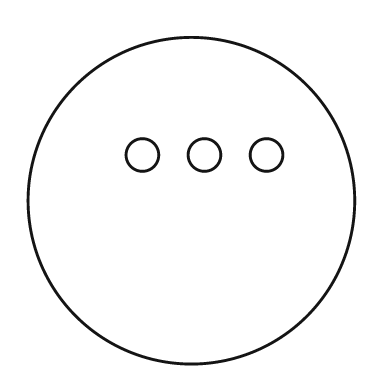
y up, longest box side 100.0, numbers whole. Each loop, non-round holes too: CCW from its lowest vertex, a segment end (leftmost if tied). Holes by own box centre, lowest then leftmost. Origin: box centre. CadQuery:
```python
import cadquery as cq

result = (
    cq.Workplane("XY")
    .moveTo(0.0, 0.0)
    .circle(50.0)
    .moveTo(-15.0, 14.0)
    .circle(5.0)
    .moveTo(4.0, 14.0)
    .circle(5.0)
    .moveTo(23.0, 14.0)
    .circle(5.0)
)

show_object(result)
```